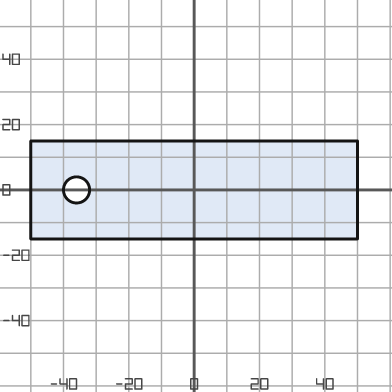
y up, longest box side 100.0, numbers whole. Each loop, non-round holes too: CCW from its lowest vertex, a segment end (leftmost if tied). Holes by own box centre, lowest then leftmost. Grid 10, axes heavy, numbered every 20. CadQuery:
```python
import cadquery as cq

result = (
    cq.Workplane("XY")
    .moveTo(-50.0, -15.0)
    .lineTo(50.0, -15.0)
    .lineTo(50.0, 15.0)
    .lineTo(-50.0, 15.0)
    .close()
    .moveTo(-36.0, 0.0)
    .circle(4.0)
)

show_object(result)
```